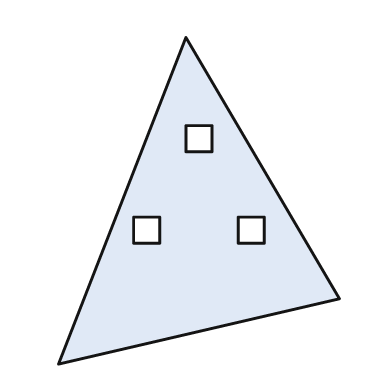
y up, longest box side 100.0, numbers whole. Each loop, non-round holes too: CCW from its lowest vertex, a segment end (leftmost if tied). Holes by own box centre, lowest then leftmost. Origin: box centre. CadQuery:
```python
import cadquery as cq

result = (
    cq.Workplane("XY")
    .moveTo(-43.0, -50.0)
    .lineTo(43.0, -30.0)
    .lineTo(-4.0, 50.0)
    .close()
    .moveTo(-20.0, -13.0)
    .lineTo(-12.0, -13.0)
    .lineTo(-12.0, -5.0)
    .lineTo(-20.0, -5.0)
    .close()
    .moveTo(12.0, -13.0)
    .lineTo(20.0, -13.0)
    .lineTo(20.0, -5.0)
    .lineTo(12.0, -5.0)
    .close()
    .moveTo(-4.0, 15.0)
    .lineTo(4.0, 15.0)
    .lineTo(4.0, 23.0)
    .lineTo(-4.0, 23.0)
    .close()
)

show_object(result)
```